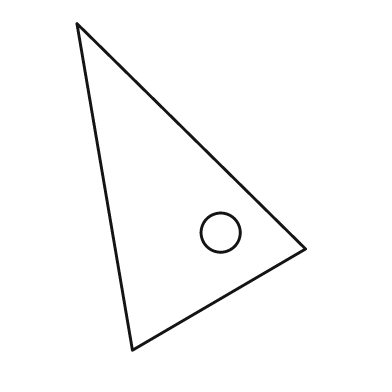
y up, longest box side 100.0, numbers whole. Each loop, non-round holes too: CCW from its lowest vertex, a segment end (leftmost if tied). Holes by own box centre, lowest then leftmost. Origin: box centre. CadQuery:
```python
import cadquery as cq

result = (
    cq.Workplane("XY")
    .moveTo(-18.0, -50.0)
    .lineTo(35.0, -19.0)
    .lineTo(-35.0, 50.0)
    .close()
    .moveTo(9.0, -14.0)
    .circle(6.0)
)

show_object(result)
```